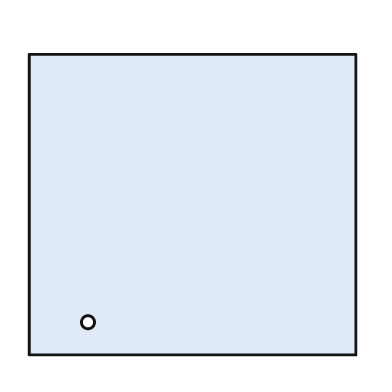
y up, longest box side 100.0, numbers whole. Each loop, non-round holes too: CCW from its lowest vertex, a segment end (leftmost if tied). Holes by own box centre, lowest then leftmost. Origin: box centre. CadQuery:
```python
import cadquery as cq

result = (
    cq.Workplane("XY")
    .moveTo(-50.0, -46.0)
    .lineTo(50.0, -46.0)
    .lineTo(50.0, 46.0)
    .lineTo(-50.0, 46.0)
    .close()
    .moveTo(-32.0, -36.0)
    .circle(2.0)
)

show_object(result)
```